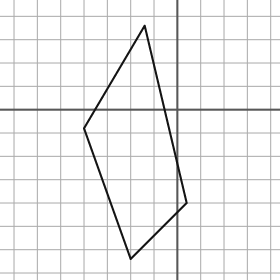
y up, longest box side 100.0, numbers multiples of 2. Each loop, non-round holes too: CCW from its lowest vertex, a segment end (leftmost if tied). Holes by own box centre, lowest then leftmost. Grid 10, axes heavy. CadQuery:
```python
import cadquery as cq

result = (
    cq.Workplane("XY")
    .moveTo(-20.0, -64.0)
    .lineTo(4.0, -40.0)
    .lineTo(-14.0, 36.0)
    .lineTo(-40.0, -8.0)
    .close()
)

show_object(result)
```